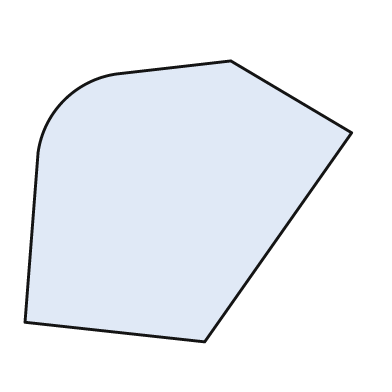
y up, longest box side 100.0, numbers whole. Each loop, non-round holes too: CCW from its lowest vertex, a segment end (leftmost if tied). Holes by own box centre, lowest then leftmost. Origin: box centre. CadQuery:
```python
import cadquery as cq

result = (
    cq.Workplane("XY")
    .moveTo(5.0, -43.0)
    .lineTo(50.0, 21.0)
    .lineTo(13.0, 43.0)
    .lineTo(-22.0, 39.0)
    .threePointArc((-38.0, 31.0), (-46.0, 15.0))
    .lineTo(-50.0, -37.0)
    .close()
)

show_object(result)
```